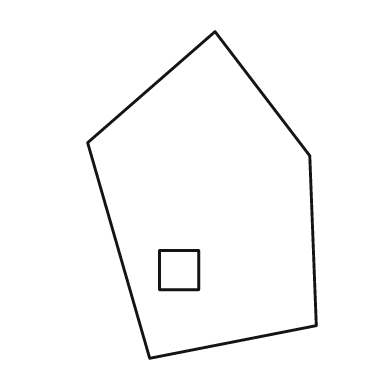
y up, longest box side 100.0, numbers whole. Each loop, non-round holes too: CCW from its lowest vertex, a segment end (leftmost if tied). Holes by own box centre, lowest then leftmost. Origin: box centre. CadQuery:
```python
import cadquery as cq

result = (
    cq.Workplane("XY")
    .moveTo(-16.0, -50.0)
    .lineTo(35.0, -40.0)
    .lineTo(33.0, 12.0)
    .lineTo(4.0, 50.0)
    .lineTo(-35.0, 16.0)
    .close()
    .moveTo(-13.0, -29.0)
    .lineTo(-1.0, -29.0)
    .lineTo(-1.0, -17.0)
    .lineTo(-13.0, -17.0)
    .close()
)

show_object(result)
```